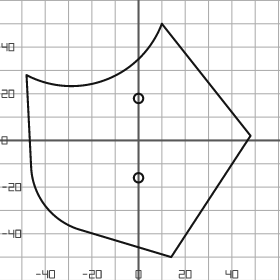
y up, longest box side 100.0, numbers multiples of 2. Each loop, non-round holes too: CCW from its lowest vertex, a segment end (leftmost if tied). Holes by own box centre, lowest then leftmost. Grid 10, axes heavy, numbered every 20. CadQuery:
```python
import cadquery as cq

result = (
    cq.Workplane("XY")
    .moveTo(14.0, -50.0)
    .lineTo(48.0, 2.0)
    .lineTo(10.0, 50.0)
    .threePointArc((-14.0, 26.0), (-48.0, 28.0))
    .lineTo(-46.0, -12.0)
    .threePointArc((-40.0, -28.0), (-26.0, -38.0))
    .close()
    .moveTo(0.0, -16.0)
    .circle(2.0)
    .moveTo(0.0, 18.0)
    .circle(2.0)
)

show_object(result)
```